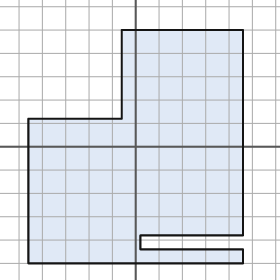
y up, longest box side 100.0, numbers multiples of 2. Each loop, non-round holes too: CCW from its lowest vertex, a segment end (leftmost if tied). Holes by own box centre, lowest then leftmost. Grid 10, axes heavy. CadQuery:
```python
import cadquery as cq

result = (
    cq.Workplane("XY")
    .moveTo(-46.0, -50.0)
    .lineTo(46.0, -50.0)
    .lineTo(46.0, -44.0)
    .lineTo(2.0, -44.0)
    .lineTo(2.0, -38.0)
    .lineTo(46.0, -38.0)
    .lineTo(46.0, 50.0)
    .lineTo(-6.0, 50.0)
    .lineTo(-6.0, 12.0)
    .lineTo(-46.0, 12.0)
    .close()
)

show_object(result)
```